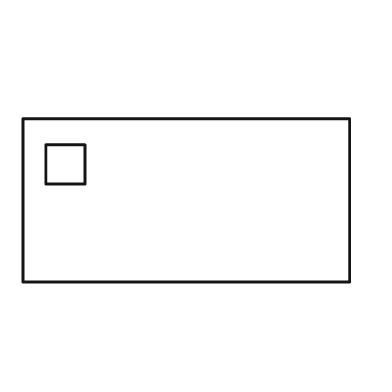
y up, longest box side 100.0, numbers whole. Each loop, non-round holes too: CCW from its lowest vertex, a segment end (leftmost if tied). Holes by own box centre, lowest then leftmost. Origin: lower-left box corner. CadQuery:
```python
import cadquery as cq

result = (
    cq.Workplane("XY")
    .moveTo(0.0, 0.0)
    .lineTo(100.0, 0.0)
    .lineTo(100.0, 50.0)
    .lineTo(0.0, 50.0)
    .close()
    .moveTo(7.0, 30.0)
    .lineTo(19.0, 30.0)
    .lineTo(19.0, 42.0)
    .lineTo(7.0, 42.0)
    .close()
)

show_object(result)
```